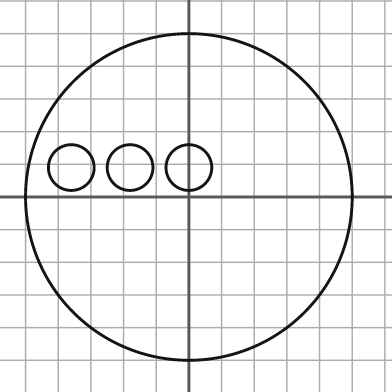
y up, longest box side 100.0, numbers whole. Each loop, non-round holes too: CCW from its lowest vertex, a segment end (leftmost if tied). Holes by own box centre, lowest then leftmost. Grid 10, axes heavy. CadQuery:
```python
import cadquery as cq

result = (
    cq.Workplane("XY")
    .moveTo(0.0, 0.0)
    .circle(50.0)
    .moveTo(-36.0, 9.0)
    .circle(7.0)
    .moveTo(-18.0, 9.0)
    .circle(7.0)
    .moveTo(0.0, 9.0)
    .circle(7.0)
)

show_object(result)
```